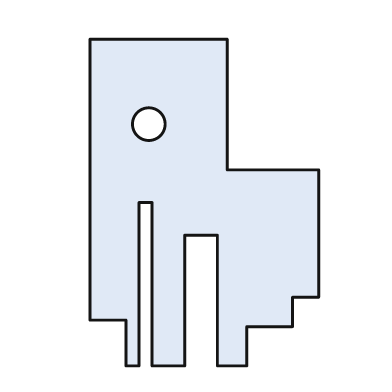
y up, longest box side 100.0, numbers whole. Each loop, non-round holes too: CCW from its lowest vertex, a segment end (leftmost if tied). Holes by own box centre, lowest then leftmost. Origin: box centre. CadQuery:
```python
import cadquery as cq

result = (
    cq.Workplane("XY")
    .moveTo(-24.0, -50.0)
    .lineTo(-20.0, -50.0)
    .lineTo(-20.0, 0.0)
    .lineTo(-16.0, 0.0)
    .lineTo(-16.0, -50.0)
    .lineTo(-6.0, -50.0)
    .lineTo(-6.0, -10.0)
    .lineTo(4.0, -10.0)
    .lineTo(4.0, -50.0)
    .lineTo(13.0, -50.0)
    .lineTo(13.0, -38.0)
    .lineTo(27.0, -38.0)
    .lineTo(27.0, -29.0)
    .lineTo(35.0, -29.0)
    .lineTo(35.0, 10.0)
    .lineTo(7.0, 10.0)
    .lineTo(7.0, 50.0)
    .lineTo(-35.0, 50.0)
    .lineTo(-35.0, -36.0)
    .lineTo(-24.0, -36.0)
    .close()
    .moveTo(-17.0, 24.0)
    .circle(5.0)
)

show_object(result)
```